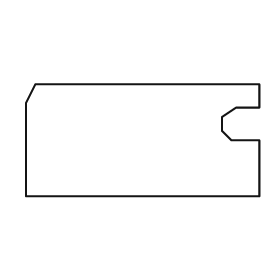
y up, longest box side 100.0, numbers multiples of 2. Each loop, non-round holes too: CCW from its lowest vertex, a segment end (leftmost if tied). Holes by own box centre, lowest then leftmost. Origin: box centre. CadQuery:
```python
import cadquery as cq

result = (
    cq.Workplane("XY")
    .moveTo(-50.0, -24.0)
    .lineTo(50.0, -24.0)
    .lineTo(50.0, 0.0)
    .lineTo(38.0, 0.0)
    .lineTo(34.0, 4.0)
    .lineTo(34.0, 10.0)
    .lineTo(40.0, 14.0)
    .lineTo(50.0, 14.0)
    .lineTo(50.0, 24.0)
    .lineTo(-46.0, 24.0)
    .lineTo(-50.0, 16.0)
    .close()
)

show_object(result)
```